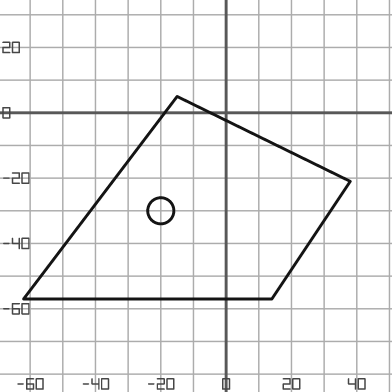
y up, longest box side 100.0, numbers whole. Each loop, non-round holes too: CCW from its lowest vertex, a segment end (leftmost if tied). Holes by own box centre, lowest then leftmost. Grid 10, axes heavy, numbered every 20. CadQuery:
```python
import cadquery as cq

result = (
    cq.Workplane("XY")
    .moveTo(-62.0, -57.0)
    .lineTo(14.0, -57.0)
    .lineTo(38.0, -21.0)
    .lineTo(-15.0, 5.0)
    .close()
    .moveTo(-20.0, -30.0)
    .circle(4.0)
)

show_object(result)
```